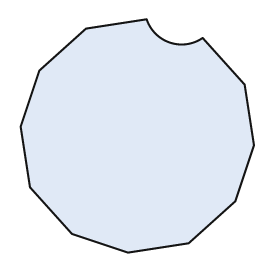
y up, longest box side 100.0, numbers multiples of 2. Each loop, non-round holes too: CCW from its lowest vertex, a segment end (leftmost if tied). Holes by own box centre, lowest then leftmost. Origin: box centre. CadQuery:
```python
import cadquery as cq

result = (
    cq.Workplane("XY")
    .moveTo(-4.0, -50.0)
    .lineTo(22.0, -46.0)
    .lineTo(42.0, -28.0)
    .lineTo(50.0, -4.0)
    .lineTo(46.0, 22.0)
    .lineTo(28.0, 42.0)
    .threePointArc((14.0, 40.0), (4.0, 50.0))
    .lineTo(-22.0, 46.0)
    .lineTo(-42.0, 28.0)
    .lineTo(-50.0, 4.0)
    .lineTo(-46.0, -22.0)
    .lineTo(-28.0, -42.0)
    .close()
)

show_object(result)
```